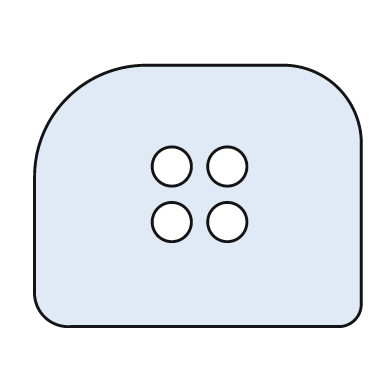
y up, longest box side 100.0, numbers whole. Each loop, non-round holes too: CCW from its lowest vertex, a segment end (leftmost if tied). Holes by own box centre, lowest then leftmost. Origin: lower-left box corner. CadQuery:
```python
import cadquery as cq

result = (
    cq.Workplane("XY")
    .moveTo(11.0, 0.0)
    .lineTo(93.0, 0.0)
    .threePointArc((98.0, 2.0), (100.0, 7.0))
    .lineTo(100.0, 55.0)
    .threePointArc((93.0, 73.0), (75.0, 80.0))
    .lineTo(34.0, 80.0)
    .threePointArc((10.0, 70.0), (0.0, 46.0))
    .lineTo(0.0, 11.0)
    .threePointArc((3.0, 3.0), (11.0, 0.0))
    .close()
    .moveTo(42.0, 32.0)
    .circle(6.0)
    .moveTo(59.0, 32.0)
    .circle(6.0)
    .moveTo(42.0, 49.0)
    .circle(6.0)
    .moveTo(59.0, 49.0)
    .circle(6.0)
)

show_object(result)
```